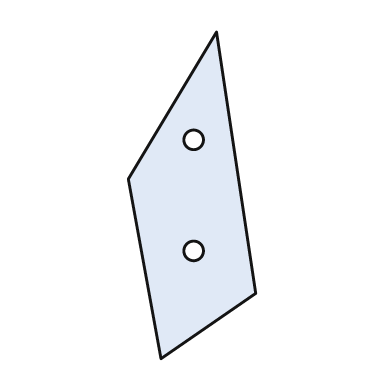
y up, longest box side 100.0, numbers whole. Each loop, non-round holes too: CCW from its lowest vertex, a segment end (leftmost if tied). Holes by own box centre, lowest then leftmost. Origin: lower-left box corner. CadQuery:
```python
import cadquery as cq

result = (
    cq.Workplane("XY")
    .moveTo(10.0, 0.0)
    .lineTo(39.0, 20.0)
    .lineTo(27.0, 100.0)
    .lineTo(0.0, 55.0)
    .close()
    .moveTo(20.0, 33.0)
    .circle(3.0)
    .moveTo(20.0, 67.0)
    .circle(3.0)
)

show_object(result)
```